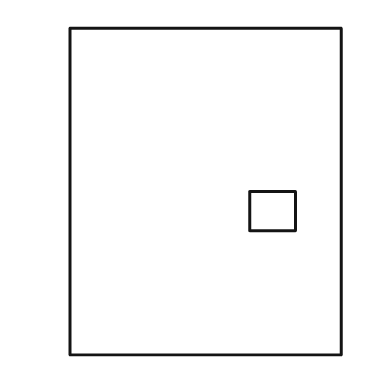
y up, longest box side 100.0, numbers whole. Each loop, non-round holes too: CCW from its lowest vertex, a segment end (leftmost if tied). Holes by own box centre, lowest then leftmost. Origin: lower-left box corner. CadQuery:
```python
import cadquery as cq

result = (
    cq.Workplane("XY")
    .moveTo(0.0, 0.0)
    .lineTo(83.0, 0.0)
    .lineTo(83.0, 100.0)
    .lineTo(0.0, 100.0)
    .close()
    .moveTo(55.0, 38.0)
    .lineTo(69.0, 38.0)
    .lineTo(69.0, 50.0)
    .lineTo(55.0, 50.0)
    .close()
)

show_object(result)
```